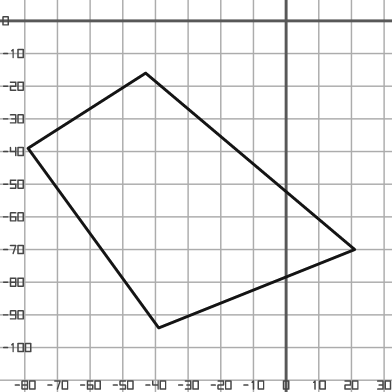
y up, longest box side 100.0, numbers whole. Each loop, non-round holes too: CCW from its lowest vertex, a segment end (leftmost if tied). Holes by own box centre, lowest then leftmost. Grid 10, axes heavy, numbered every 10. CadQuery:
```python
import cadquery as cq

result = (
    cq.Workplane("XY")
    .moveTo(-39.0, -94.0)
    .lineTo(21.0, -70.0)
    .lineTo(-43.0, -16.0)
    .lineTo(-79.0, -39.0)
    .close()
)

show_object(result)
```